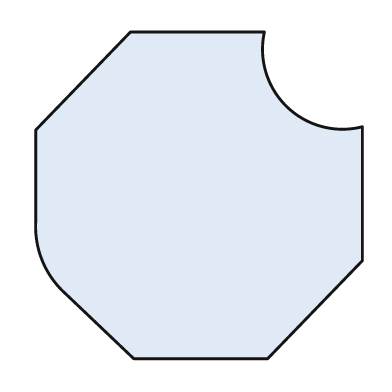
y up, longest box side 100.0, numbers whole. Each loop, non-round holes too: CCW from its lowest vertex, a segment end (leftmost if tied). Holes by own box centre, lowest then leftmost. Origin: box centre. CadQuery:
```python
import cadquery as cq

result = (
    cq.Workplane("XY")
    .moveTo(-20.0, -50.0)
    .lineTo(21.0, -50.0)
    .lineTo(50.0, -20.0)
    .lineTo(50.0, 21.0)
    .threePointArc((27.0, 27.0), (20.0, 50.0))
    .lineTo(-21.0, 50.0)
    .lineTo(-50.0, 20.0)
    .lineTo(-50.0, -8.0)
    .threePointArc((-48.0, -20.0), (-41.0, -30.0))
    .close()
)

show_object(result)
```